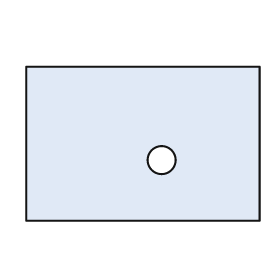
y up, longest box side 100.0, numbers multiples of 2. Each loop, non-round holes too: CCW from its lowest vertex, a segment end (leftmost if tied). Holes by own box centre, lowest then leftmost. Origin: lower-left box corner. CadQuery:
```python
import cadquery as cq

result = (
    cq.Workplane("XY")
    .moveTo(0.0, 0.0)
    .lineTo(100.0, 0.0)
    .lineTo(100.0, 66.0)
    .lineTo(0.0, 66.0)
    .close()
    .moveTo(58.0, 26.0)
    .circle(6.0)
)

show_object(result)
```